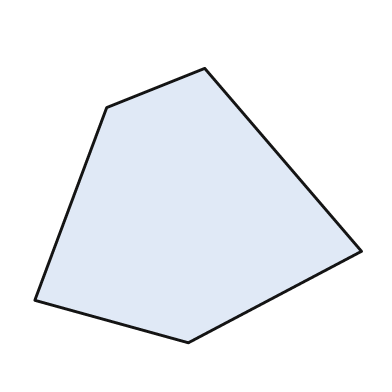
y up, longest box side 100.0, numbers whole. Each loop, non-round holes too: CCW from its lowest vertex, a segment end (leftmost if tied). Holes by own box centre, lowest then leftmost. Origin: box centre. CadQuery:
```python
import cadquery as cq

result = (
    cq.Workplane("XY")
    .moveTo(-3.0, -42.0)
    .lineTo(50.0, -14.0)
    .lineTo(2.0, 42.0)
    .lineTo(-28.0, 30.0)
    .lineTo(-50.0, -29.0)
    .close()
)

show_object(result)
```